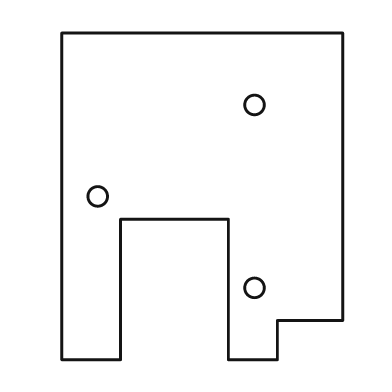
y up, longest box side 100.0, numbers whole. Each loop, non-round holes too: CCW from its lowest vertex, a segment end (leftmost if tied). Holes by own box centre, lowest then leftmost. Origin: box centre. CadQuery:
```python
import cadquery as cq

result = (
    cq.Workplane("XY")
    .moveTo(-43.0, -50.0)
    .lineTo(-25.0, -50.0)
    .lineTo(-25.0, -7.0)
    .lineTo(8.0, -7.0)
    .lineTo(8.0, -50.0)
    .lineTo(23.0, -50.0)
    .lineTo(23.0, -38.0)
    .lineTo(43.0, -38.0)
    .lineTo(43.0, 50.0)
    .lineTo(-43.0, 50.0)
    .close()
    .moveTo(16.0, -28.0)
    .circle(3.0)
    .moveTo(-32.0, 0.0)
    .circle(3.0)
    .moveTo(16.0, 28.0)
    .circle(3.0)
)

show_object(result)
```